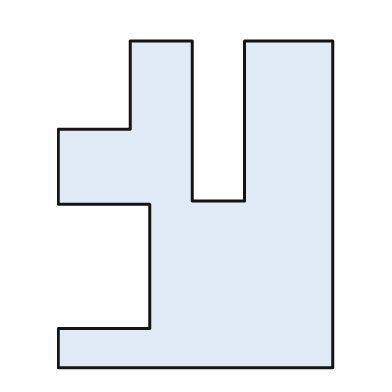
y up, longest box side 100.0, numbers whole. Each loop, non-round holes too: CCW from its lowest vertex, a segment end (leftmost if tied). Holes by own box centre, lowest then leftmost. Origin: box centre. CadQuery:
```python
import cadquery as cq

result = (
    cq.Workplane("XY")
    .moveTo(-42.0, -50.0)
    .lineTo(42.0, -50.0)
    .lineTo(42.0, 50.0)
    .lineTo(15.0, 50.0)
    .lineTo(15.0, 1.0)
    .lineTo(-1.0, 1.0)
    .lineTo(-1.0, 50.0)
    .lineTo(-20.0, 50.0)
    .lineTo(-20.0, 23.0)
    .lineTo(-42.0, 23.0)
    .lineTo(-42.0, 0.0)
    .lineTo(-14.0, 0.0)
    .lineTo(-14.0, -38.0)
    .lineTo(-42.0, -38.0)
    .close()
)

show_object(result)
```